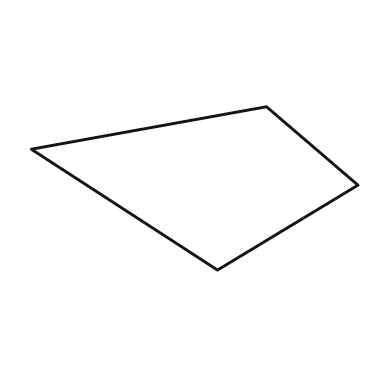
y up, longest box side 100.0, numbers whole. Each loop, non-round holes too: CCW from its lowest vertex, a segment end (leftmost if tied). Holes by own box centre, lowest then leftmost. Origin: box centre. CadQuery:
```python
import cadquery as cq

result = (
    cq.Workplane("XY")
    .moveTo(7.0, -25.0)
    .lineTo(50.0, 1.0)
    .lineTo(22.0, 25.0)
    .lineTo(-50.0, 12.0)
    .close()
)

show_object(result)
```